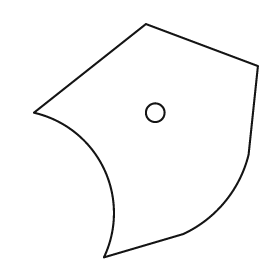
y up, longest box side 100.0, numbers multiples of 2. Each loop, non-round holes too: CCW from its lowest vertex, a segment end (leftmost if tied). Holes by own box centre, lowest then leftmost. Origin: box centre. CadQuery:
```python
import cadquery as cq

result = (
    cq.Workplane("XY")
    .moveTo(-18.0, -50.0)
    .lineTo(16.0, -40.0)
    .threePointArc((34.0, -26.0), (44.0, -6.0))
    .lineTo(48.0, 32.0)
    .lineTo(0.0, 50.0)
    .lineTo(-48.0, 12.0)
    .threePointArc((-18.0, -12.0), (-18.0, -50.0))
    .close()
    .moveTo(4.0, 12.0)
    .circle(4.0)
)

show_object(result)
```